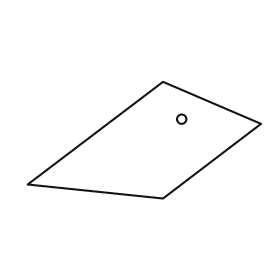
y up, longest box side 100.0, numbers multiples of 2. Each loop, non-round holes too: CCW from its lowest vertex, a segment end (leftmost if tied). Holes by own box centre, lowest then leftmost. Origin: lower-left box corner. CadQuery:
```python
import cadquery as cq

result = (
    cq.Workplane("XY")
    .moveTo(58.0, 0.0)
    .lineTo(100.0, 32.0)
    .lineTo(58.0, 50.0)
    .lineTo(0.0, 6.0)
    .close()
    .moveTo(66.0, 34.0)
    .circle(2.0)
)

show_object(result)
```